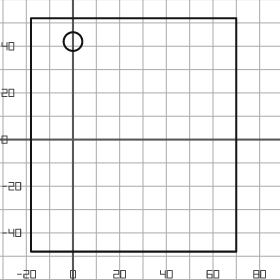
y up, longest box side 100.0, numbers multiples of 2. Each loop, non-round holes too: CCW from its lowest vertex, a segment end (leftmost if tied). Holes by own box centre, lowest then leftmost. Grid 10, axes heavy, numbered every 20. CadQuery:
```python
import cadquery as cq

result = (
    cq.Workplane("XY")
    .moveTo(-18.0, -48.0)
    .lineTo(70.0, -48.0)
    .lineTo(70.0, 52.0)
    .lineTo(-18.0, 52.0)
    .close()
    .moveTo(0.0, 42.0)
    .circle(4.0)
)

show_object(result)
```